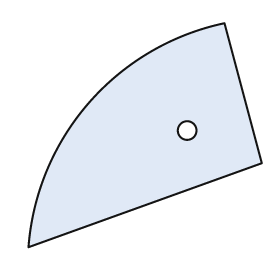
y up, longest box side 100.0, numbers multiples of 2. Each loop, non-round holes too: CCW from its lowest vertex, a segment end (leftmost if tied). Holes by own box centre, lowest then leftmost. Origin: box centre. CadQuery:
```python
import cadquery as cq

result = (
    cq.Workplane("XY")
    .moveTo(-50.0, -48.0)
    .lineTo(50.0, -12.0)
    .lineTo(34.0, 48.0)
    .threePointArc((-24.0, 14.0), (-50.0, -48.0))
    .close()
    .moveTo(18.0, 2.0)
    .circle(4.0)
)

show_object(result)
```